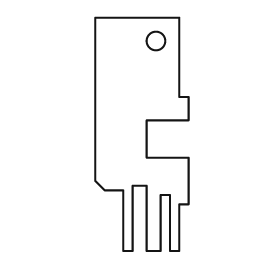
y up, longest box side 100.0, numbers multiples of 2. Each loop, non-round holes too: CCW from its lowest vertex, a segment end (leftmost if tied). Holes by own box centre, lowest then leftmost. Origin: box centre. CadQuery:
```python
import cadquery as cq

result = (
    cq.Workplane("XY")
    .moveTo(-8.0, -50.0)
    .lineTo(-4.0, -50.0)
    .lineTo(-4.0, -22.0)
    .lineTo(2.0, -22.0)
    .lineTo(2.0, -50.0)
    .lineTo(8.0, -50.0)
    .lineTo(8.0, -26.0)
    .lineTo(12.0, -26.0)
    .lineTo(12.0, -50.0)
    .lineTo(16.0, -50.0)
    .lineTo(16.0, -30.0)
    .lineTo(20.0, -30.0)
    .lineTo(20.0, -10.0)
    .lineTo(2.0, -10.0)
    .lineTo(2.0, 6.0)
    .lineTo(20.0, 6.0)
    .lineTo(20.0, 16.0)
    .lineTo(16.0, 16.0)
    .lineTo(16.0, 50.0)
    .lineTo(-20.0, 50.0)
    .lineTo(-20.0, -20.0)
    .lineTo(-16.0, -24.0)
    .lineTo(-8.0, -24.0)
    .close()
    .moveTo(6.0, 40.0)
    .circle(4.0)
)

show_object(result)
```